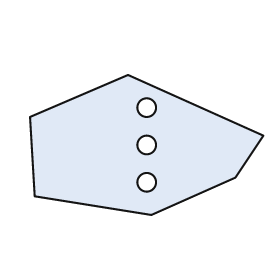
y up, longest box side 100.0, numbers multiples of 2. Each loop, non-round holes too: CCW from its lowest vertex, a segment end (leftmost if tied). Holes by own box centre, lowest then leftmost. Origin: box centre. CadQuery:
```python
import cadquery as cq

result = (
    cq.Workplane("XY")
    .moveTo(2.0, -30.0)
    .lineTo(38.0, -14.0)
    .lineTo(50.0, 4.0)
    .lineTo(-8.0, 30.0)
    .lineTo(-50.0, 12.0)
    .lineTo(-48.0, -22.0)
    .close()
    .moveTo(0.0, -16.0)
    .circle(4.0)
    .moveTo(0.0, 0.0)
    .circle(4.0)
    .moveTo(0.0, 16.0)
    .circle(4.0)
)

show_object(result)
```